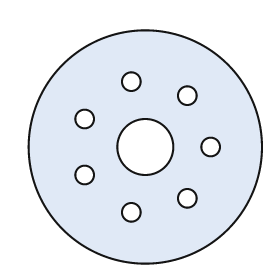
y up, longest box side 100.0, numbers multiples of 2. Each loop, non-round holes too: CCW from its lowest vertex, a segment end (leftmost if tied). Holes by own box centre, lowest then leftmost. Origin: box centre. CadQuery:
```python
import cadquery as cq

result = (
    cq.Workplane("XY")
    .moveTo(0.0, 0.0)
    .circle(50.0)
    .moveTo(-6.0, -28.0)
    .circle(4.0)
    .moveTo(18.0, -22.0)
    .circle(4.0)
    .moveTo(-26.0, -12.0)
    .circle(4.0)
    .moveTo(0.0, 0.0)
    .circle(12.0)
    .moveTo(28.0, 0.0)
    .circle(4.0)
    .moveTo(-26.0, 12.0)
    .circle(4.0)
    .moveTo(18.0, 22.0)
    .circle(4.0)
    .moveTo(-6.0, 28.0)
    .circle(4.0)
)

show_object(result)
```